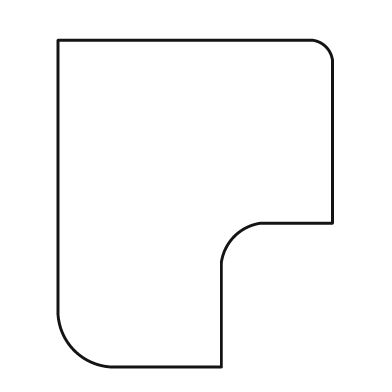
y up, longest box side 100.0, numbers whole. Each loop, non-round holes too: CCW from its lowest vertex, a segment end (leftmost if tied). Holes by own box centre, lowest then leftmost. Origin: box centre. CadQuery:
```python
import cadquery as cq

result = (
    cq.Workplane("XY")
    .moveTo(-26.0, -50.0)
    .lineTo(8.0, -50.0)
    .lineTo(8.0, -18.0)
    .threePointArc((12.0, -10.0), (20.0, -6.0))
    .lineTo(42.0, -6.0)
    .lineTo(42.0, 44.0)
    .threePointArc((40.0, 48.0), (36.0, 50.0))
    .lineTo(-42.0, 50.0)
    .lineTo(-42.0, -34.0)
    .threePointArc((-37.0, -45.0), (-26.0, -50.0))
    .close()
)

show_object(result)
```